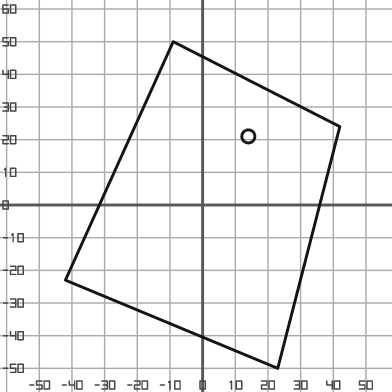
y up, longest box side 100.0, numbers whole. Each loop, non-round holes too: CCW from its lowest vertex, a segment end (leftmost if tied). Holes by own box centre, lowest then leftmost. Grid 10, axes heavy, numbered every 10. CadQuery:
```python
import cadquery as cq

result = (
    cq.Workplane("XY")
    .moveTo(23.0, -50.0)
    .lineTo(42.0, 24.0)
    .lineTo(-9.0, 50.0)
    .lineTo(-42.0, -23.0)
    .close()
    .moveTo(14.0, 21.0)
    .circle(2.0)
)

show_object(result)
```